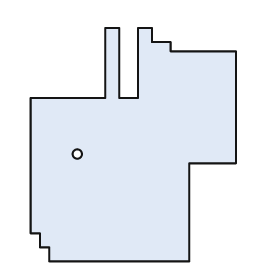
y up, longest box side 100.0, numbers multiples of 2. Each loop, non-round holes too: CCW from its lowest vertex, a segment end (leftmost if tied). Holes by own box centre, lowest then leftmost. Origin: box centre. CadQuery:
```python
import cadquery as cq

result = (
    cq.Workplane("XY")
    .moveTo(-36.0, -50.0)
    .lineTo(24.0, -50.0)
    .lineTo(24.0, -8.0)
    .lineTo(44.0, -8.0)
    .lineTo(44.0, 40.0)
    .lineTo(16.0, 40.0)
    .lineTo(16.0, 44.0)
    .lineTo(8.0, 44.0)
    .lineTo(8.0, 50.0)
    .lineTo(2.0, 50.0)
    .lineTo(2.0, 20.0)
    .lineTo(-6.0, 20.0)
    .lineTo(-6.0, 50.0)
    .lineTo(-12.0, 50.0)
    .lineTo(-12.0, 20.0)
    .lineTo(-44.0, 20.0)
    .lineTo(-44.0, -38.0)
    .lineTo(-40.0, -38.0)
    .lineTo(-40.0, -44.0)
    .lineTo(-36.0, -44.0)
    .close()
    .moveTo(-24.0, -4.0)
    .circle(2.0)
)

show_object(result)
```